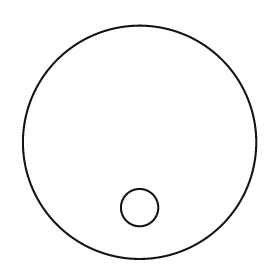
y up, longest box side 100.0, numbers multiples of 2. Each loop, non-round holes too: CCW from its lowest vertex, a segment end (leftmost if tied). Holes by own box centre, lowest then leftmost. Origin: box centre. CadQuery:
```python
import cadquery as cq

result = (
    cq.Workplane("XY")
    .moveTo(0.0, 0.0)
    .circle(50.0)
    .moveTo(0.0, -28.0)
    .circle(8.0)
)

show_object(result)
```